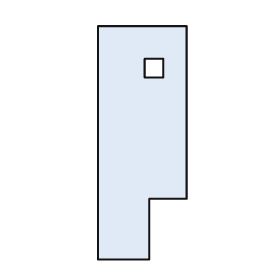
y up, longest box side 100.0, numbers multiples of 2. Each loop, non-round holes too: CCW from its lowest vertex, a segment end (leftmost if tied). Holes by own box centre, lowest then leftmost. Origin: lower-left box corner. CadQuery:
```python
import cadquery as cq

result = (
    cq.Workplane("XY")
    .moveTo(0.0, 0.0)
    .lineTo(22.0, 0.0)
    .lineTo(22.0, 26.0)
    .lineTo(38.0, 26.0)
    .lineTo(38.0, 100.0)
    .lineTo(0.0, 100.0)
    .close()
    .moveTo(20.0, 78.0)
    .lineTo(28.0, 78.0)
    .lineTo(28.0, 86.0)
    .lineTo(20.0, 86.0)
    .close()
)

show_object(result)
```